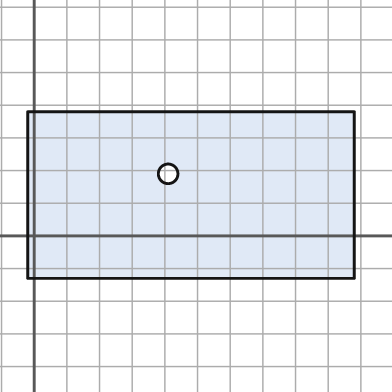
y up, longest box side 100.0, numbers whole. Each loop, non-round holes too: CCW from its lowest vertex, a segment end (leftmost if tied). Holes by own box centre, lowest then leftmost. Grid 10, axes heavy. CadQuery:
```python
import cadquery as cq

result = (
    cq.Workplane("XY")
    .moveTo(-2.0, -13.0)
    .lineTo(98.0, -13.0)
    .lineTo(98.0, 38.0)
    .lineTo(-2.0, 38.0)
    .close()
    .moveTo(41.0, 19.0)
    .circle(3.0)
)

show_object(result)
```